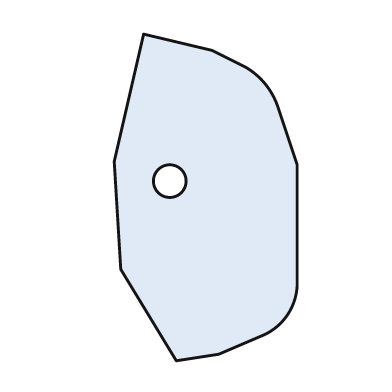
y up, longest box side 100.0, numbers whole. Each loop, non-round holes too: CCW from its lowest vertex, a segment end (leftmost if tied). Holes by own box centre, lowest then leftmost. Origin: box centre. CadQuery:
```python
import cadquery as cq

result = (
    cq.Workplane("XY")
    .moveTo(-9.0, -50.0)
    .lineTo(4.0, -48.0)
    .lineTo(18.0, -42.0)
    .threePointArc((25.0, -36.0), (28.0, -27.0))
    .lineTo(28.0, 10.0)
    .lineTo(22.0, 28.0)
    .threePointArc((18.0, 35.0), (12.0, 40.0))
    .lineTo(2.0, 45.0)
    .lineTo(-19.0, 50.0)
    .lineTo(-28.0, 11.0)
    .lineTo(-26.0, -22.0)
    .close()
    .moveTo(-11.0, 5.0)
    .circle(5.0)
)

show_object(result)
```